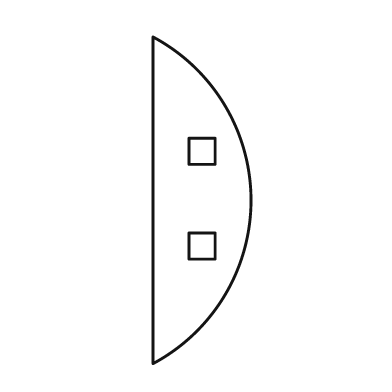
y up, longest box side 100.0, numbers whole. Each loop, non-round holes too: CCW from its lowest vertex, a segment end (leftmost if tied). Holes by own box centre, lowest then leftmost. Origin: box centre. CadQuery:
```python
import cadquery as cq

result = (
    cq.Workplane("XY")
    .moveTo(-15.0, -50.0)
    .threePointArc((15.0, 0.0), (-15.0, 50.0))
    .close()
    .moveTo(-4.0, -18.0)
    .lineTo(4.0, -18.0)
    .lineTo(4.0, -10.0)
    .lineTo(-4.0, -10.0)
    .close()
    .moveTo(-4.0, 11.0)
    .lineTo(4.0, 11.0)
    .lineTo(4.0, 19.0)
    .lineTo(-4.0, 19.0)
    .close()
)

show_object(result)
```